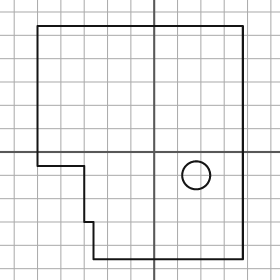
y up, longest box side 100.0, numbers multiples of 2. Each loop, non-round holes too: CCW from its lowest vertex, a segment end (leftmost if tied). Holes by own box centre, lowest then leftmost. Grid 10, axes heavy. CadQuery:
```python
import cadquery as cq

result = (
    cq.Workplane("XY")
    .moveTo(-26.0, -46.0)
    .lineTo(38.0, -46.0)
    .lineTo(38.0, 54.0)
    .lineTo(-50.0, 54.0)
    .lineTo(-50.0, -6.0)
    .lineTo(-30.0, -6.0)
    .lineTo(-30.0, -30.0)
    .lineTo(-26.0, -30.0)
    .close()
    .moveTo(18.0, -10.0)
    .circle(6.0)
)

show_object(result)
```